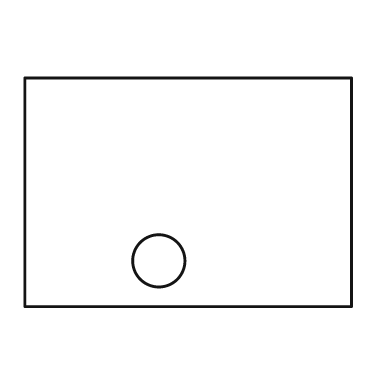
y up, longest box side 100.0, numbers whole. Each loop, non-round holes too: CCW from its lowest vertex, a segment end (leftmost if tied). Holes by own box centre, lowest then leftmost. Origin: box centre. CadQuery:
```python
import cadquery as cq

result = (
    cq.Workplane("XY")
    .moveTo(-50.0, -35.0)
    .lineTo(50.0, -35.0)
    .lineTo(50.0, 35.0)
    .lineTo(-50.0, 35.0)
    .close()
    .moveTo(-9.0, -21.0)
    .circle(8.0)
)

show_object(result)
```